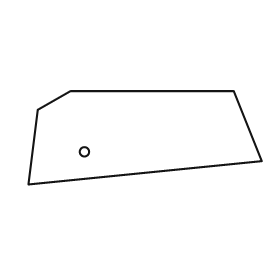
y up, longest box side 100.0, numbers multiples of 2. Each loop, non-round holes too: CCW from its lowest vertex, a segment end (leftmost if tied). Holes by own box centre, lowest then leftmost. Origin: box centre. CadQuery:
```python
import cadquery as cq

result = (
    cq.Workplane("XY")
    .moveTo(-50.0, -20.0)
    .lineTo(50.0, -10.0)
    .lineTo(38.0, 20.0)
    .lineTo(-32.0, 20.0)
    .lineTo(-46.0, 12.0)
    .close()
    .moveTo(-26.0, -6.0)
    .circle(2.0)
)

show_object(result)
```